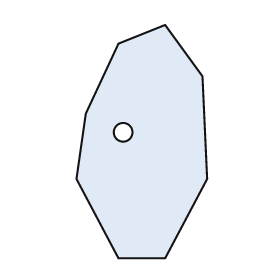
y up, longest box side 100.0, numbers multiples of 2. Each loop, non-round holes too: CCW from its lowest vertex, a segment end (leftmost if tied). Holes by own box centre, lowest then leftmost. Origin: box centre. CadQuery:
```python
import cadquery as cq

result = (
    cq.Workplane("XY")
    .moveTo(-10.0, -50.0)
    .lineTo(10.0, -50.0)
    .lineTo(28.0, -16.0)
    .lineTo(26.0, 28.0)
    .lineTo(10.0, 50.0)
    .lineTo(-10.0, 42.0)
    .lineTo(-24.0, 12.0)
    .lineTo(-28.0, -16.0)
    .close()
    .moveTo(-8.0, 4.0)
    .circle(4.0)
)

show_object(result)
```